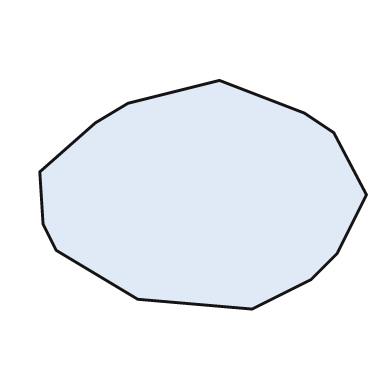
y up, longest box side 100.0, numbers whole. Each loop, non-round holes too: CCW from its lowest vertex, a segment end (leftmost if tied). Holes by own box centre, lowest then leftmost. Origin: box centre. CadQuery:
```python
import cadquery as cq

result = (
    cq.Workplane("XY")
    .moveTo(15.0, -35.0)
    .lineTo(33.0, -26.0)
    .lineTo(41.0, -18.0)
    .lineTo(50.0, 0.0)
    .lineTo(40.0, 19.0)
    .lineTo(31.0, 25.0)
    .lineTo(5.0, 35.0)
    .lineTo(-23.0, 28.0)
    .lineTo(-33.0, 22.0)
    .lineTo(-50.0, 7.0)
    .lineTo(-49.0, -9.0)
    .lineTo(-45.0, -17.0)
    .lineTo(-20.0, -32.0)
    .close()
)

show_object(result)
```